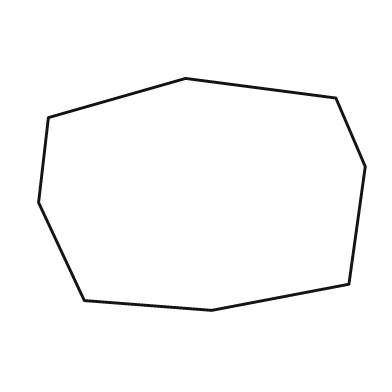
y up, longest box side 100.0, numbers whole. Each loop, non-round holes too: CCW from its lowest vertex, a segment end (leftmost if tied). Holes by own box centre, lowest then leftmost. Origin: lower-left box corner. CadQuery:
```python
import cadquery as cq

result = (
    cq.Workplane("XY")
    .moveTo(53.0, 0.0)
    .lineTo(95.0, 8.0)
    .lineTo(100.0, 44.0)
    .lineTo(91.0, 65.0)
    .lineTo(45.0, 71.0)
    .lineTo(3.0, 59.0)
    .lineTo(0.0, 33.0)
    .lineTo(14.0, 3.0)
    .close()
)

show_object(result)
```